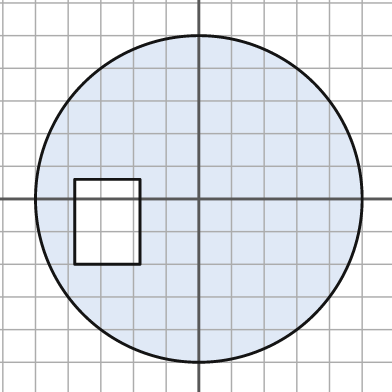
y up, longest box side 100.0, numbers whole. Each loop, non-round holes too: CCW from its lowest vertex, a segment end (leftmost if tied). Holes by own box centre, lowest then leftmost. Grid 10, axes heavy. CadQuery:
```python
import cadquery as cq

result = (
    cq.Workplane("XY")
    .moveTo(0.0, 0.0)
    .circle(50.0)
    .moveTo(-38.0, -20.0)
    .lineTo(-18.0, -20.0)
    .lineTo(-18.0, 6.0)
    .lineTo(-38.0, 6.0)
    .close()
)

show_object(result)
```